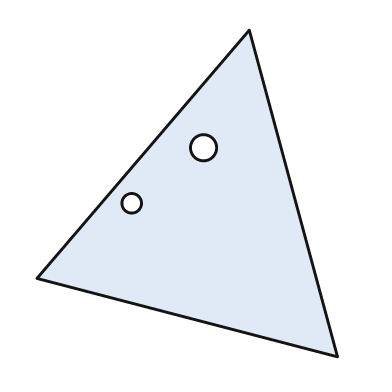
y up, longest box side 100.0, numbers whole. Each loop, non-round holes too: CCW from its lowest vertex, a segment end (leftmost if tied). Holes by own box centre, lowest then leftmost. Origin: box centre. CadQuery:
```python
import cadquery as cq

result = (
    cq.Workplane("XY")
    .moveTo(46.0, -50.0)
    .lineTo(19.0, 50.0)
    .lineTo(-46.0, -26.0)
    .close()
    .moveTo(-17.0, -3.0)
    .circle(3.0)
    .moveTo(5.0, 14.0)
    .circle(4.0)
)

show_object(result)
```